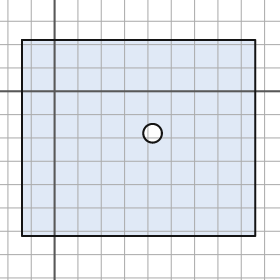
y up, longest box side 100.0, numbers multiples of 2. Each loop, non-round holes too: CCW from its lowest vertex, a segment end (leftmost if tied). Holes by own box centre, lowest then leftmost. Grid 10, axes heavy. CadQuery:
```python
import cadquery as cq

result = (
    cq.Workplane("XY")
    .moveTo(-14.0, -62.0)
    .lineTo(86.0, -62.0)
    .lineTo(86.0, 22.0)
    .lineTo(-14.0, 22.0)
    .close()
    .moveTo(42.0, -18.0)
    .circle(4.0)
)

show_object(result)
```